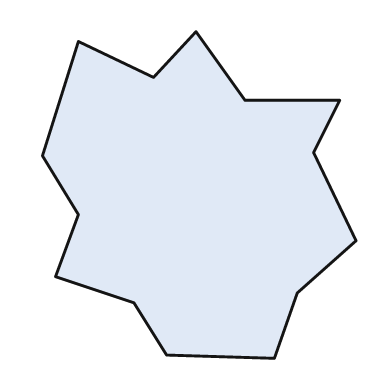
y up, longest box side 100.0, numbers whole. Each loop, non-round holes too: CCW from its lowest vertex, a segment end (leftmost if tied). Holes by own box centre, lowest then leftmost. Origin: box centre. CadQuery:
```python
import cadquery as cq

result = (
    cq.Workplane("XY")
    .moveTo(23.0, -50.0)
    .lineTo(30.0, -30.0)
    .lineTo(48.0, -14.0)
    .lineTo(35.0, 13.0)
    .lineTo(43.0, 29.0)
    .lineTo(14.0, 29.0)
    .lineTo(-1.0, 50.0)
    .lineTo(-14.0, 36.0)
    .lineTo(-37.0, 47.0)
    .lineTo(-48.0, 12.0)
    .lineTo(-37.0, -6.0)
    .lineTo(-44.0, -25.0)
    .lineTo(-20.0, -33.0)
    .lineTo(-10.0, -49.0)
    .close()
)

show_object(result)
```